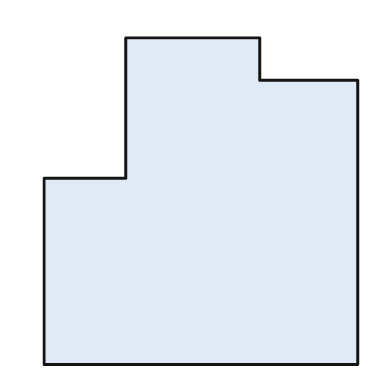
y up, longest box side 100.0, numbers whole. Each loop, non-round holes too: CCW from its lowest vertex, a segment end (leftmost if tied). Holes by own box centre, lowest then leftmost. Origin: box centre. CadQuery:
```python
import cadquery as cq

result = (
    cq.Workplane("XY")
    .moveTo(-48.0, -50.0)
    .lineTo(48.0, -50.0)
    .lineTo(48.0, 37.0)
    .lineTo(18.0, 37.0)
    .lineTo(18.0, 50.0)
    .lineTo(-23.0, 50.0)
    .lineTo(-23.0, 7.0)
    .lineTo(-48.0, 7.0)
    .close()
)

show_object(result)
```